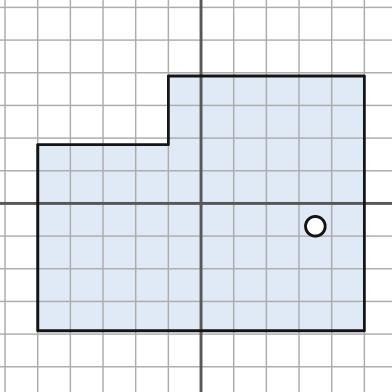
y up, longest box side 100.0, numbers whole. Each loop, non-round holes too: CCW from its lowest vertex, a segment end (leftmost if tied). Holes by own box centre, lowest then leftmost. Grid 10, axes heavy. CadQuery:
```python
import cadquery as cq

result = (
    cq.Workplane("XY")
    .moveTo(-50.0, -39.0)
    .lineTo(50.0, -39.0)
    .lineTo(50.0, 39.0)
    .lineTo(-10.0, 39.0)
    .lineTo(-10.0, 18.0)
    .lineTo(-50.0, 18.0)
    .close()
    .moveTo(35.0, -7.0)
    .circle(3.0)
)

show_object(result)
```